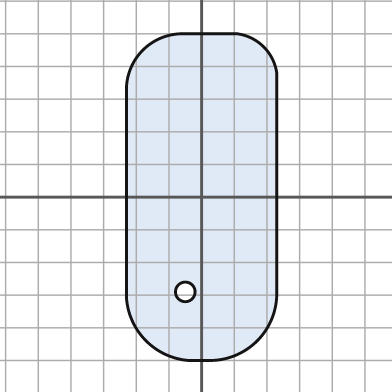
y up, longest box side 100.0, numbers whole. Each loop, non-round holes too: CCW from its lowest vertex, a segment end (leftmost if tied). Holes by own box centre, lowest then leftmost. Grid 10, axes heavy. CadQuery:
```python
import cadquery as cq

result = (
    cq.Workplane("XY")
    .moveTo(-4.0, -50.0)
    .lineTo(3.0, -50.0)
    .threePointArc((17.0, -44.0), (23.0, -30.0))
    .lineTo(23.0, 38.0)
    .threePointArc((19.0, 46.0), (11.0, 50.0))
    .lineTo(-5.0, 50.0)
    .threePointArc((-18.0, 45.0), (-23.0, 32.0))
    .lineTo(-23.0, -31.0)
    .threePointArc((-17.0, -44.0), (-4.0, -50.0))
    .close()
    .moveTo(-5.0, -29.0)
    .circle(3.0)
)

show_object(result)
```